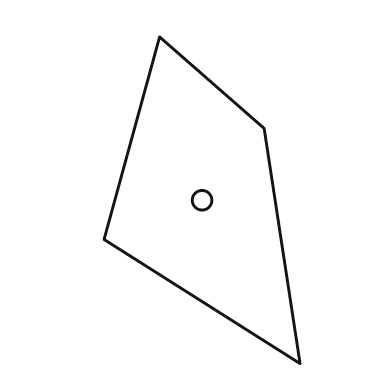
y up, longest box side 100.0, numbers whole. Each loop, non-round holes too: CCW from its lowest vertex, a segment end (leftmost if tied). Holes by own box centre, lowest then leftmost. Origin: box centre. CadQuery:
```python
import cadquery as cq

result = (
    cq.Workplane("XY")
    .moveTo(30.0, -50.0)
    .lineTo(19.0, 22.0)
    .lineTo(-13.0, 50.0)
    .lineTo(-30.0, -12.0)
    .close()
    .moveTo(0.0, 0.0)
    .circle(3.0)
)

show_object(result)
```